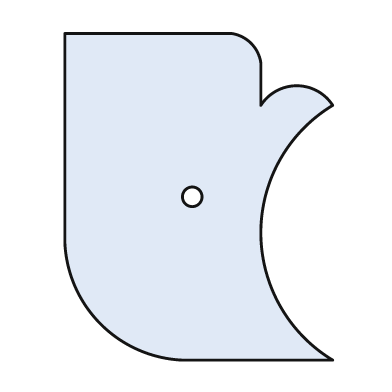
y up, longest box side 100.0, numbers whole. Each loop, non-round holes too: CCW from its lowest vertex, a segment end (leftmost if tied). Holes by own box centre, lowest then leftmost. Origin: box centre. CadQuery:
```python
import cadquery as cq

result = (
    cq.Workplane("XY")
    .moveTo(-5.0, -50.0)
    .lineTo(41.0, -50.0)
    .threePointArc((19.0, -11.0), (41.0, 28.0))
    .threePointArc((30.0, 34.0), (19.0, 28.0))
    .lineTo(19.0, 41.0)
    .threePointArc((16.0, 47.0), (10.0, 50.0))
    .lineTo(-41.0, 50.0)
    .lineTo(-41.0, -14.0)
    .threePointArc((-30.0, -39.0), (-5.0, -50.0))
    .close()
    .moveTo(-2.0, 0.0)
    .circle(3.0)
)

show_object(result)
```